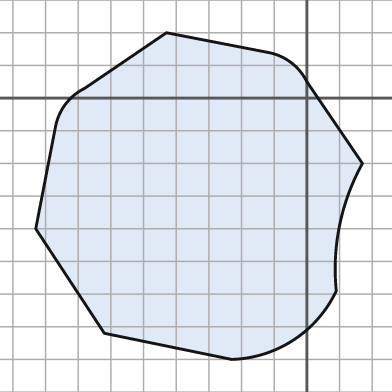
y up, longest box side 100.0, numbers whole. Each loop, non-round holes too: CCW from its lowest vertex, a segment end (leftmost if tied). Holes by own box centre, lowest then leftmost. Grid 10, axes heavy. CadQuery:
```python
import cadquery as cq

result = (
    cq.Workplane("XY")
    .moveTo(-23.0, -80.0)
    .threePointArc((-4.0, -74.0), (9.0, -59.0))
    .threePointArc((10.0, -39.0), (17.0, -20.0))
    .lineTo(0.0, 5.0)
    .threePointArc((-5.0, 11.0), (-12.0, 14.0))
    .lineTo(-43.0, 20.0)
    .lineTo(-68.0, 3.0)
    .threePointArc((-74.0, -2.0), (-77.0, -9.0))
    .lineTo(-83.0, -40.0)
    .lineTo(-62.0, -72.0)
    .close()
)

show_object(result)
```